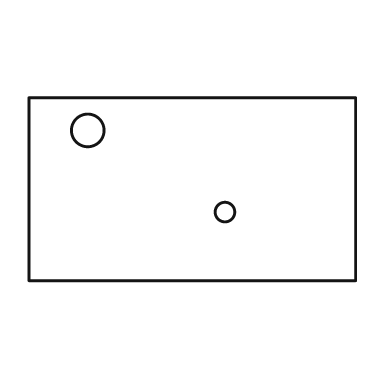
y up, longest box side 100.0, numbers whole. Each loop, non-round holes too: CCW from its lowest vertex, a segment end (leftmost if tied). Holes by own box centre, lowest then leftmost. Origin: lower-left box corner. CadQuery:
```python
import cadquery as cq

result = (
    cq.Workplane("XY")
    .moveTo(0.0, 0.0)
    .lineTo(100.0, 0.0)
    .lineTo(100.0, 56.0)
    .lineTo(0.0, 56.0)
    .close()
    .moveTo(60.0, 21.0)
    .circle(3.0)
    .moveTo(18.0, 46.0)
    .circle(5.0)
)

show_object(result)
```